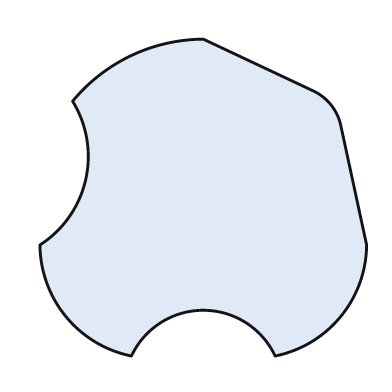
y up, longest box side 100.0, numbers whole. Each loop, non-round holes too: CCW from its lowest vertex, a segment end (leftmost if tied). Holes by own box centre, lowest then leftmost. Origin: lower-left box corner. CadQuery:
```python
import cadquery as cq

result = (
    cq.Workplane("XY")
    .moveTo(28.0, 0.0)
    .threePointArc((50.0, 14.0), (72.0, 0.0))
    .threePointArc((92.0, 12.0), (100.0, 34.0))
    .lineTo(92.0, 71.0)
    .threePointArc((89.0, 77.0), (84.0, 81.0))
    .lineTo(50.0, 97.0)
    .threePointArc((28.0, 92.0), (10.0, 78.0))
    .threePointArc((14.0, 54.0), (0.0, 34.0))
    .threePointArc((8.0, 12.0), (28.0, 0.0))
    .close()
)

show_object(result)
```